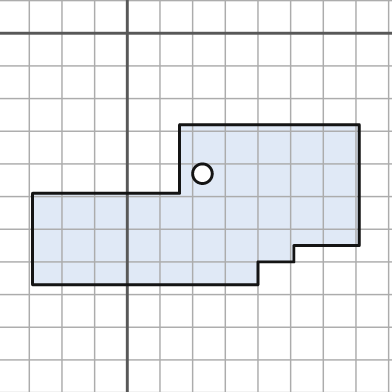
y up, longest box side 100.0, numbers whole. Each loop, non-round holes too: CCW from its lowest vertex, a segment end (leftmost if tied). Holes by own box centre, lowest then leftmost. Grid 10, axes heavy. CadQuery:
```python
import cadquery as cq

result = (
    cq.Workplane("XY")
    .moveTo(-29.0, -77.0)
    .lineTo(40.0, -77.0)
    .lineTo(40.0, -70.0)
    .lineTo(51.0, -70.0)
    .lineTo(51.0, -65.0)
    .lineTo(71.0, -65.0)
    .lineTo(71.0, -28.0)
    .lineTo(16.0, -28.0)
    .lineTo(16.0, -49.0)
    .lineTo(-29.0, -49.0)
    .close()
    .moveTo(23.0, -43.0)
    .circle(3.0)
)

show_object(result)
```